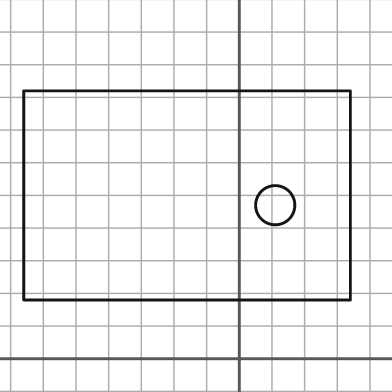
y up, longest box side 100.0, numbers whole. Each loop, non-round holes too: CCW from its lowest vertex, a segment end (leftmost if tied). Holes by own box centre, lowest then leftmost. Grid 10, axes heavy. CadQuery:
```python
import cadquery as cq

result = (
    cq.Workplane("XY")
    .moveTo(-66.0, 18.0)
    .lineTo(34.0, 18.0)
    .lineTo(34.0, 82.0)
    .lineTo(-66.0, 82.0)
    .close()
    .moveTo(11.0, 47.0)
    .circle(6.0)
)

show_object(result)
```